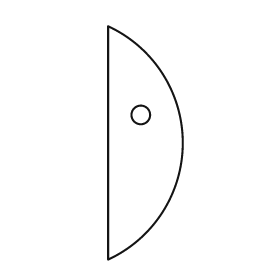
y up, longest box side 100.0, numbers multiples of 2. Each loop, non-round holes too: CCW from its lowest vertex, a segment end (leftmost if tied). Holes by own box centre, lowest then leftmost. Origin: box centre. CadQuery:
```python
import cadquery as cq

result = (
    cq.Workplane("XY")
    .moveTo(-16.0, -50.0)
    .threePointArc((16.0, 0.0), (-16.0, 50.0))
    .close()
    .moveTo(-2.0, 12.0)
    .circle(4.0)
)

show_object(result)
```